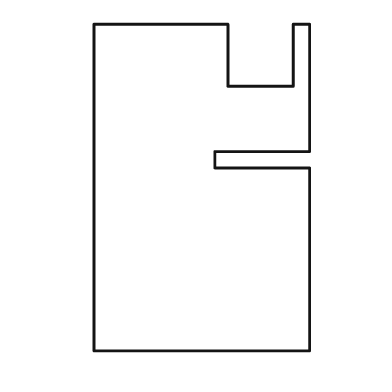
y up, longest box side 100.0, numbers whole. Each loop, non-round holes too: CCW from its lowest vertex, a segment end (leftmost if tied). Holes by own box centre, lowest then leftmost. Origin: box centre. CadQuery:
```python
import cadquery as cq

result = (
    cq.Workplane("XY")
    .moveTo(-33.0, -50.0)
    .lineTo(33.0, -50.0)
    .lineTo(33.0, 6.0)
    .lineTo(4.0, 6.0)
    .lineTo(4.0, 11.0)
    .lineTo(33.0, 11.0)
    .lineTo(33.0, 50.0)
    .lineTo(28.0, 50.0)
    .lineTo(28.0, 31.0)
    .lineTo(8.0, 31.0)
    .lineTo(8.0, 50.0)
    .lineTo(-33.0, 50.0)
    .close()
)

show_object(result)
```